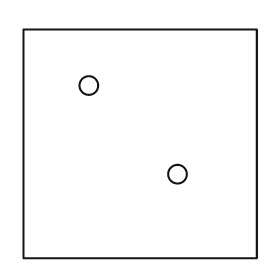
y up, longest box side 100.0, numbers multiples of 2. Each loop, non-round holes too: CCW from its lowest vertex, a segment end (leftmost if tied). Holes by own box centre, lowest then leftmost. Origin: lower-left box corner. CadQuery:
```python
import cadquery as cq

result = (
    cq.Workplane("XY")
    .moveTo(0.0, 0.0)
    .lineTo(100.0, 0.0)
    .lineTo(100.0, 98.0)
    .lineTo(0.0, 98.0)
    .close()
    .moveTo(66.0, 36.0)
    .circle(4.0)
    .moveTo(28.0, 74.0)
    .circle(4.0)
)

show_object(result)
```